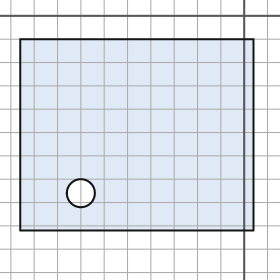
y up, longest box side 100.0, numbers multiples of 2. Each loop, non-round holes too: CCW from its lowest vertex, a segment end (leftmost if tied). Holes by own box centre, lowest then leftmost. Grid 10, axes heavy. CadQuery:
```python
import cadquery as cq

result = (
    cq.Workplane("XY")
    .moveTo(-96.0, -92.0)
    .lineTo(4.0, -92.0)
    .lineTo(4.0, -10.0)
    .lineTo(-96.0, -10.0)
    .close()
    .moveTo(-70.0, -76.0)
    .circle(6.0)
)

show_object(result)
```